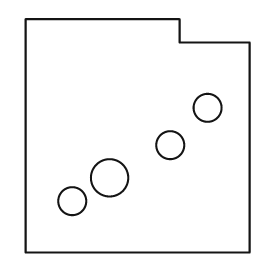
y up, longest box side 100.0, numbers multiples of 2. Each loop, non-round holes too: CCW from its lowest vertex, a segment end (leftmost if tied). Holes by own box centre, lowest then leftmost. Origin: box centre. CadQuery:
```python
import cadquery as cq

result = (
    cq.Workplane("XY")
    .moveTo(-48.0, -50.0)
    .lineTo(48.0, -50.0)
    .lineTo(48.0, 40.0)
    .lineTo(18.0, 40.0)
    .lineTo(18.0, 50.0)
    .lineTo(-48.0, 50.0)
    .close()
    .moveTo(-28.0, -28.0)
    .circle(6.0)
    .moveTo(-12.0, -18.0)
    .circle(8.0)
    .moveTo(14.0, -4.0)
    .circle(6.0)
    .moveTo(30.0, 12.0)
    .circle(6.0)
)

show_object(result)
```